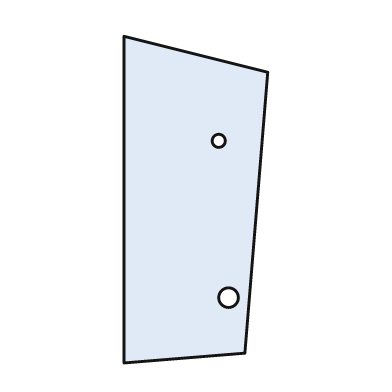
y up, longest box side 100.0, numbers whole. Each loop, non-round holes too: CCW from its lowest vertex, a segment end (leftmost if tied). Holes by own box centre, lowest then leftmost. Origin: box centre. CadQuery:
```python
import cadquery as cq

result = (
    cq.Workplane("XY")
    .moveTo(-22.0, -50.0)
    .lineTo(15.0, -47.0)
    .lineTo(22.0, 39.0)
    .lineTo(-22.0, 50.0)
    .close()
    .moveTo(10.0, -30.0)
    .circle(3.0)
    .moveTo(7.0, 18.0)
    .circle(2.0)
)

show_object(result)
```